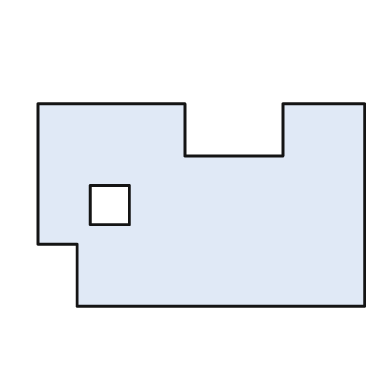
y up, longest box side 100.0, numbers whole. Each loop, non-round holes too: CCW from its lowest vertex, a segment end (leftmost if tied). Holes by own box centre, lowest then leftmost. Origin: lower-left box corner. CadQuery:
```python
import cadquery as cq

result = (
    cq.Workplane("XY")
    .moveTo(12.0, 0.0)
    .lineTo(100.0, 0.0)
    .lineTo(100.0, 62.0)
    .lineTo(75.0, 62.0)
    .lineTo(75.0, 46.0)
    .lineTo(45.0, 46.0)
    .lineTo(45.0, 62.0)
    .lineTo(0.0, 62.0)
    .lineTo(0.0, 19.0)
    .lineTo(12.0, 19.0)
    .close()
    .moveTo(16.0, 25.0)
    .lineTo(28.0, 25.0)
    .lineTo(28.0, 37.0)
    .lineTo(16.0, 37.0)
    .close()
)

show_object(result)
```